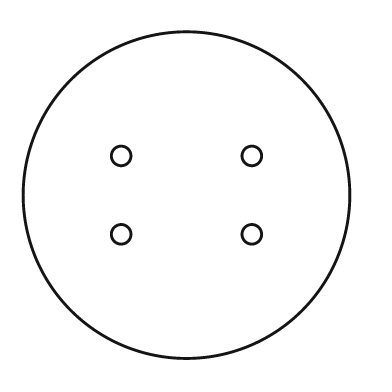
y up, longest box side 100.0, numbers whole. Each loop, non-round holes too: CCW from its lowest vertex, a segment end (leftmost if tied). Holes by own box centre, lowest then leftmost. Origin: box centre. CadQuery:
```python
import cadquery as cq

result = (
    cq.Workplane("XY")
    .moveTo(0.0, 0.0)
    .circle(50.0)
    .moveTo(-20.0, -12.0)
    .circle(3.0)
    .moveTo(20.0, -12.0)
    .circle(3.0)
    .moveTo(-20.0, 12.0)
    .circle(3.0)
    .moveTo(20.0, 12.0)
    .circle(3.0)
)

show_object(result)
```